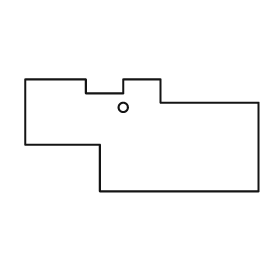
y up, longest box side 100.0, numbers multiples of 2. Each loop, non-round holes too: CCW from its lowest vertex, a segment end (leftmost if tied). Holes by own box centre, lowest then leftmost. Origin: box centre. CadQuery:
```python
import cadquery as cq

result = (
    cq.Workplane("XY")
    .moveTo(-18.0, -24.0)
    .lineTo(50.0, -24.0)
    .lineTo(50.0, 14.0)
    .lineTo(8.0, 14.0)
    .lineTo(8.0, 24.0)
    .lineTo(-8.0, 24.0)
    .lineTo(-8.0, 18.0)
    .lineTo(-24.0, 18.0)
    .lineTo(-24.0, 24.0)
    .lineTo(-50.0, 24.0)
    .lineTo(-50.0, -4.0)
    .lineTo(-18.0, -4.0)
    .close()
    .moveTo(-8.0, 12.0)
    .circle(2.0)
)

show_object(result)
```